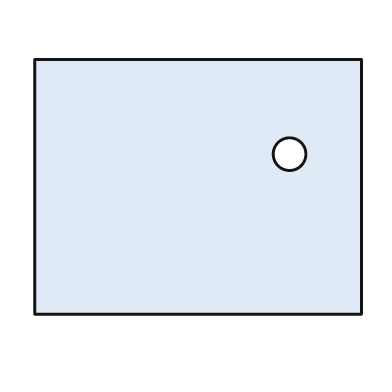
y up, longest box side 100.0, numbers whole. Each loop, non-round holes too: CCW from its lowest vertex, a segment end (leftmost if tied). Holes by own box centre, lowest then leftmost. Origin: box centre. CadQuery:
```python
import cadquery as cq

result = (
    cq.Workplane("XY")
    .moveTo(-50.0, -39.0)
    .lineTo(50.0, -39.0)
    .lineTo(50.0, 39.0)
    .lineTo(-50.0, 39.0)
    .close()
    .moveTo(28.0, 10.0)
    .circle(5.0)
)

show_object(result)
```